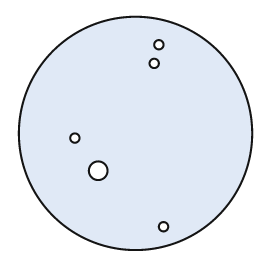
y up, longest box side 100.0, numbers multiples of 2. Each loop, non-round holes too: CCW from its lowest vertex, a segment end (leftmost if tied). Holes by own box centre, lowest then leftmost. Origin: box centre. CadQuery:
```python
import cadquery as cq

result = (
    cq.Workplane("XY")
    .moveTo(0.0, 0.0)
    .circle(50.0)
    .moveTo(12.0, -40.0)
    .circle(2.0)
    .moveTo(-16.0, -16.0)
    .circle(4.0)
    .moveTo(-26.0, -2.0)
    .circle(2.0)
    .moveTo(8.0, 30.0)
    .circle(2.0)
    .moveTo(10.0, 38.0)
    .circle(2.0)
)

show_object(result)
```